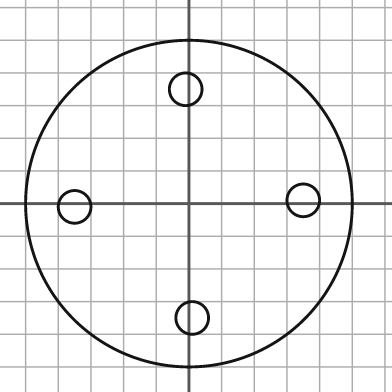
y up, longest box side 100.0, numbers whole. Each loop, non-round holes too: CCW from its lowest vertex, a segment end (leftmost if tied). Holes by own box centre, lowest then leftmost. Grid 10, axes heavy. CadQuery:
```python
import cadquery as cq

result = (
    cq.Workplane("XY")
    .moveTo(0.0, 0.0)
    .circle(50.0)
    .moveTo(1.0, -35.0)
    .circle(5.0)
    .moveTo(-35.0, -1.0)
    .circle(5.0)
    .moveTo(35.0, 1.0)
    .circle(5.0)
    .moveTo(-1.0, 35.0)
    .circle(5.0)
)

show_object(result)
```